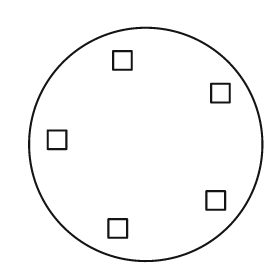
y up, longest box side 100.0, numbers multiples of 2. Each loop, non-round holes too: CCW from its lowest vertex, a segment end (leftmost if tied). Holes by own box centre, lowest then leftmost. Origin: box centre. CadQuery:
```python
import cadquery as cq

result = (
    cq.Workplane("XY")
    .moveTo(0.0, 0.0)
    .circle(50.0)
    .moveTo(-16.0, -40.0)
    .lineTo(-8.0, -40.0)
    .lineTo(-8.0, -32.0)
    .lineTo(-16.0, -32.0)
    .close()
    .moveTo(26.0, -28.0)
    .lineTo(34.0, -28.0)
    .lineTo(34.0, -20.0)
    .lineTo(26.0, -20.0)
    .close()
    .moveTo(-42.0, -2.0)
    .lineTo(-34.0, -2.0)
    .lineTo(-34.0, 6.0)
    .lineTo(-42.0, 6.0)
    .close()
    .moveTo(28.0, 18.0)
    .lineTo(36.0, 18.0)
    .lineTo(36.0, 26.0)
    .lineTo(28.0, 26.0)
    .close()
    .moveTo(-14.0, 32.0)
    .lineTo(-6.0, 32.0)
    .lineTo(-6.0, 40.0)
    .lineTo(-14.0, 40.0)
    .close()
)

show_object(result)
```